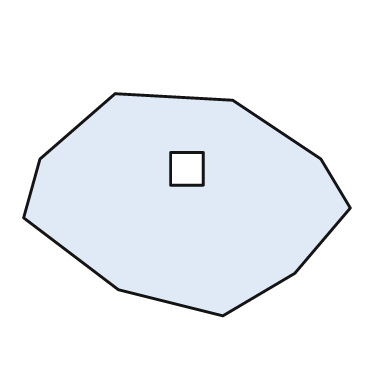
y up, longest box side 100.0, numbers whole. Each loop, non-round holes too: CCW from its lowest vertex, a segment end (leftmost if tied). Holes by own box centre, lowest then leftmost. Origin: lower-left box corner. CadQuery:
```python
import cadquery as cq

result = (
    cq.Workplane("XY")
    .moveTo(61.0, 0.0)
    .lineTo(83.0, 13.0)
    .lineTo(100.0, 33.0)
    .lineTo(91.0, 48.0)
    .lineTo(64.0, 66.0)
    .lineTo(28.0, 68.0)
    .lineTo(5.0, 48.0)
    .lineTo(0.0, 30.0)
    .lineTo(29.0, 8.0)
    .close()
    .moveTo(45.0, 40.0)
    .lineTo(55.0, 40.0)
    .lineTo(55.0, 50.0)
    .lineTo(45.0, 50.0)
    .close()
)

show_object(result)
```